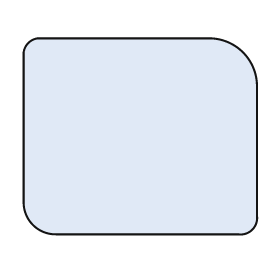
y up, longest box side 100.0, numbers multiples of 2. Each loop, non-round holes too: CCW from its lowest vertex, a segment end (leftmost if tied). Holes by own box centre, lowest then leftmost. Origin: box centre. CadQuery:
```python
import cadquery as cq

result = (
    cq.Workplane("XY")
    .moveTo(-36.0, -42.0)
    .lineTo(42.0, -42.0)
    .threePointArc((48.0, -40.0), (50.0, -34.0))
    .lineTo(50.0, 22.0)
    .threePointArc((44.0, 36.0), (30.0, 42.0))
    .lineTo(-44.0, 42.0)
    .threePointArc((-48.0, 40.0), (-50.0, 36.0))
    .lineTo(-50.0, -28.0)
    .threePointArc((-46.0, -38.0), (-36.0, -42.0))
    .close()
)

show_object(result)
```